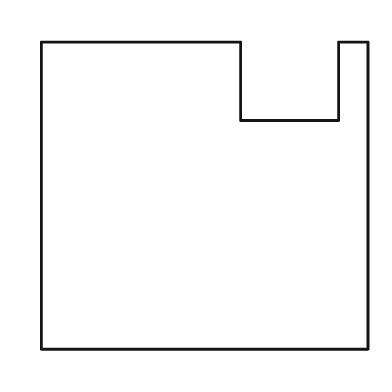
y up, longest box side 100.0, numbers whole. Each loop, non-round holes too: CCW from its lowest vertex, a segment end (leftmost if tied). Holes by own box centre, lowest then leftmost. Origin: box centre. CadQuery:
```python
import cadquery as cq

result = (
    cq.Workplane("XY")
    .moveTo(-50.0, -47.0)
    .lineTo(50.0, -47.0)
    .lineTo(50.0, 47.0)
    .lineTo(41.0, 47.0)
    .lineTo(41.0, 23.0)
    .lineTo(11.0, 23.0)
    .lineTo(11.0, 47.0)
    .lineTo(-50.0, 47.0)
    .close()
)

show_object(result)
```